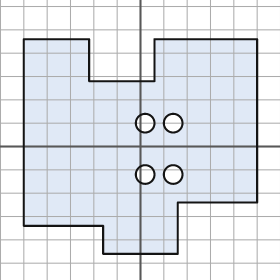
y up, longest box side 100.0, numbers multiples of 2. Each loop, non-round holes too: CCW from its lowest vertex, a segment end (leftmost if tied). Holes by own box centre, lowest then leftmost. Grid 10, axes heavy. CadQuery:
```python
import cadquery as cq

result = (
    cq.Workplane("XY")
    .moveTo(-16.0, -46.0)
    .lineTo(16.0, -46.0)
    .lineTo(16.0, -24.0)
    .lineTo(50.0, -24.0)
    .lineTo(50.0, 46.0)
    .lineTo(6.0, 46.0)
    .lineTo(6.0, 28.0)
    .lineTo(-22.0, 28.0)
    .lineTo(-22.0, 46.0)
    .lineTo(-50.0, 46.0)
    .lineTo(-50.0, -34.0)
    .lineTo(-16.0, -34.0)
    .close()
    .moveTo(2.0, -12.0)
    .circle(4.0)
    .moveTo(14.0, -12.0)
    .circle(4.0)
    .moveTo(2.0, 10.0)
    .circle(4.0)
    .moveTo(14.0, 10.0)
    .circle(4.0)
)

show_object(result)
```